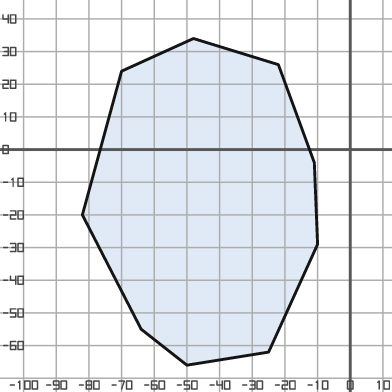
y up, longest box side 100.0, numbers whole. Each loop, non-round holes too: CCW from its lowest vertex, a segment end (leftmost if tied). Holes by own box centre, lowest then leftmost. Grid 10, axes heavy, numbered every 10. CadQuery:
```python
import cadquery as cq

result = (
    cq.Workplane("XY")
    .moveTo(-50.0, -66.0)
    .lineTo(-25.0, -62.0)
    .lineTo(-10.0, -29.0)
    .lineTo(-11.0, -4.0)
    .lineTo(-22.0, 26.0)
    .lineTo(-48.0, 34.0)
    .lineTo(-70.0, 24.0)
    .lineTo(-82.0, -20.0)
    .lineTo(-64.0, -55.0)
    .close()
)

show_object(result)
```